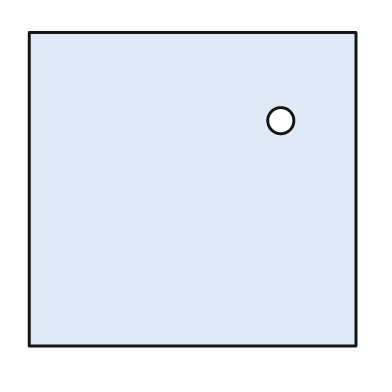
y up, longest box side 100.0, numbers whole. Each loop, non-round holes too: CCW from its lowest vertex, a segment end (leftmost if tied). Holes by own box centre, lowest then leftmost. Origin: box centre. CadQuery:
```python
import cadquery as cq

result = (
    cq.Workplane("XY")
    .moveTo(-50.0, -48.0)
    .lineTo(50.0, -48.0)
    .lineTo(50.0, 48.0)
    .lineTo(-50.0, 48.0)
    .close()
    .moveTo(27.0, 21.0)
    .circle(4.0)
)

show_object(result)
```